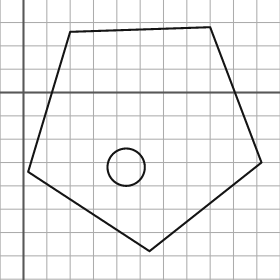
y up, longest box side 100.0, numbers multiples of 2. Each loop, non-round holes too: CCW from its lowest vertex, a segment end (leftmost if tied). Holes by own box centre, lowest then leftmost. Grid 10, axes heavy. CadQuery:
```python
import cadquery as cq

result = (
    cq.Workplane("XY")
    .moveTo(54.0, -68.0)
    .lineTo(102.0, -30.0)
    .lineTo(80.0, 28.0)
    .lineTo(20.0, 26.0)
    .lineTo(2.0, -34.0)
    .close()
    .moveTo(44.0, -32.0)
    .circle(8.0)
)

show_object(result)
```